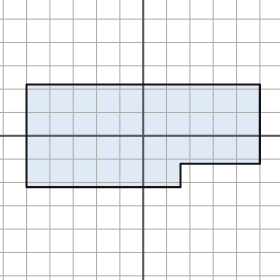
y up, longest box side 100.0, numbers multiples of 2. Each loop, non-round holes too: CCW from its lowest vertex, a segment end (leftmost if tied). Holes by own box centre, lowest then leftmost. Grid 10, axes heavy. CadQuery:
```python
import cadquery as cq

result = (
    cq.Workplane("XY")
    .moveTo(-50.0, -22.0)
    .lineTo(16.0, -22.0)
    .lineTo(16.0, -12.0)
    .lineTo(50.0, -12.0)
    .lineTo(50.0, 22.0)
    .lineTo(-50.0, 22.0)
    .close()
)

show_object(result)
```